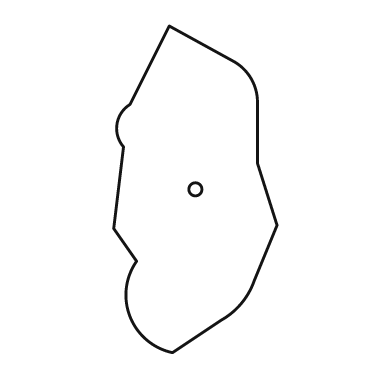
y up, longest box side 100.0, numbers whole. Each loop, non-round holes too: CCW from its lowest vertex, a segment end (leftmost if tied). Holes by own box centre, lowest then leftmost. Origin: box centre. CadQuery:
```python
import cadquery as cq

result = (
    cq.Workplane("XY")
    .moveTo(-7.0, -50.0)
    .lineTo(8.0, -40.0)
    .threePointArc((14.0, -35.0), (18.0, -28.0))
    .lineTo(25.0, -11.0)
    .lineTo(19.0, 8.0)
    .lineTo(19.0, 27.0)
    .threePointArc((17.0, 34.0), (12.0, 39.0))
    .lineTo(-8.0, 50.0)
    .lineTo(-20.0, 26.0)
    .threePointArc((-24.0, 20.0), (-22.0, 13.0))
    .lineTo(-25.0, -12.0)
    .lineTo(-18.0, -22.0)
    .threePointArc((-20.0, -39.0), (-7.0, -50.0))
    .close()
    .moveTo(0.0, 0.0)
    .circle(2.0)
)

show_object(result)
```